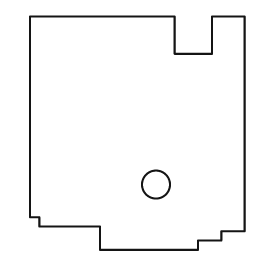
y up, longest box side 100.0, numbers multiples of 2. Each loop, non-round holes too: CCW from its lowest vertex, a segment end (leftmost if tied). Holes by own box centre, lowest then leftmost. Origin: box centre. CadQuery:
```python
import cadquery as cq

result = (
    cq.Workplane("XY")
    .moveTo(-16.0, -50.0)
    .lineTo(26.0, -50.0)
    .lineTo(26.0, -46.0)
    .lineTo(36.0, -46.0)
    .lineTo(36.0, -42.0)
    .lineTo(46.0, -42.0)
    .lineTo(46.0, 50.0)
    .lineTo(32.0, 50.0)
    .lineTo(32.0, 34.0)
    .lineTo(16.0, 34.0)
    .lineTo(16.0, 50.0)
    .lineTo(-46.0, 50.0)
    .lineTo(-46.0, -36.0)
    .lineTo(-42.0, -36.0)
    .lineTo(-42.0, -40.0)
    .lineTo(-16.0, -40.0)
    .close()
    .moveTo(8.0, -22.0)
    .circle(6.0)
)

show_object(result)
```